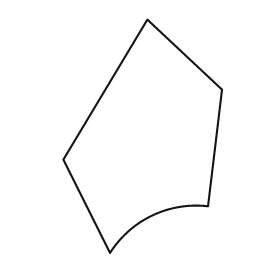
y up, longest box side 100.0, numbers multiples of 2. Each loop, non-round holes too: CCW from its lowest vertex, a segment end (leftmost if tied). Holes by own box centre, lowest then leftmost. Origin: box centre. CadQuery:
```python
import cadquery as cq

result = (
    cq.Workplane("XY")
    .moveTo(-14.0, -50.0)
    .threePointArc((4.0, -34.0), (28.0, -30.0))
    .lineTo(34.0, 20.0)
    .lineTo(2.0, 50.0)
    .lineTo(-34.0, -10.0)
    .close()
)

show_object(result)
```